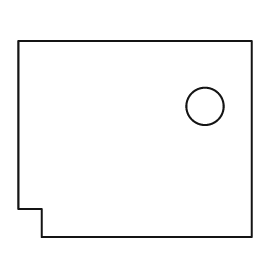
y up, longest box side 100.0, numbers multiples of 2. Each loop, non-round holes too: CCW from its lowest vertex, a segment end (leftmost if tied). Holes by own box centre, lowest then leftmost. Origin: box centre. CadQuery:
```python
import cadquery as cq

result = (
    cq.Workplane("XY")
    .moveTo(-40.0, -42.0)
    .lineTo(50.0, -42.0)
    .lineTo(50.0, 42.0)
    .lineTo(-50.0, 42.0)
    .lineTo(-50.0, -30.0)
    .lineTo(-40.0, -30.0)
    .close()
    .moveTo(30.0, 14.0)
    .circle(8.0)
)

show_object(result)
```